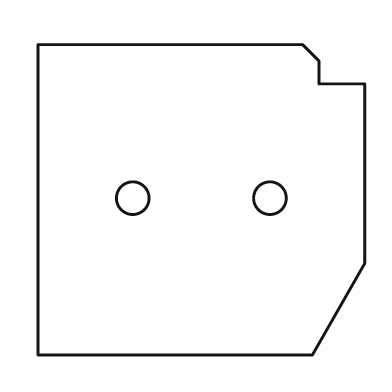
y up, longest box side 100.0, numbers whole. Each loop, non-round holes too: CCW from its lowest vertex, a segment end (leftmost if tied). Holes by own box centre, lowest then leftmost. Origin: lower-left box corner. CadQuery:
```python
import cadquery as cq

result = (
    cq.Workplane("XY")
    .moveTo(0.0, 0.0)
    .lineTo(84.0, 0.0)
    .lineTo(100.0, 28.0)
    .lineTo(100.0, 83.0)
    .lineTo(86.0, 83.0)
    .lineTo(86.0, 90.0)
    .lineTo(81.0, 95.0)
    .lineTo(0.0, 95.0)
    .close()
    .moveTo(29.0, 48.0)
    .circle(5.0)
    .moveTo(71.0, 48.0)
    .circle(5.0)
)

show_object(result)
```